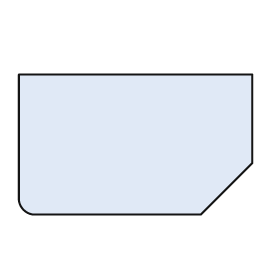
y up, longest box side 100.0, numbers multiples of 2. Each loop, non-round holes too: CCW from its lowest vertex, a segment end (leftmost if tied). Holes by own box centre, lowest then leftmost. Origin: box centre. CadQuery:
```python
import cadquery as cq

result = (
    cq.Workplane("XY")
    .moveTo(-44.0, -30.0)
    .lineTo(28.0, -30.0)
    .lineTo(50.0, -8.0)
    .lineTo(50.0, 30.0)
    .lineTo(-50.0, 30.0)
    .lineTo(-50.0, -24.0)
    .threePointArc((-48.0, -28.0), (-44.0, -30.0))
    .close()
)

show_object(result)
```